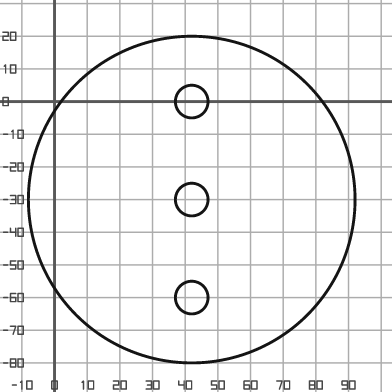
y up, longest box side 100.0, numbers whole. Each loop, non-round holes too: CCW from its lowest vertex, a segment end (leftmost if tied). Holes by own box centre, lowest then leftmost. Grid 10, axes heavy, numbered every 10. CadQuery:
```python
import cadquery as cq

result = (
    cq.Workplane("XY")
    .moveTo(42.0, -30.0)
    .circle(50.0)
    .moveTo(42.0, -60.0)
    .circle(5.0)
    .moveTo(42.0, -30.0)
    .circle(5.0)
    .moveTo(42.0, 0.0)
    .circle(5.0)
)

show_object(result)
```